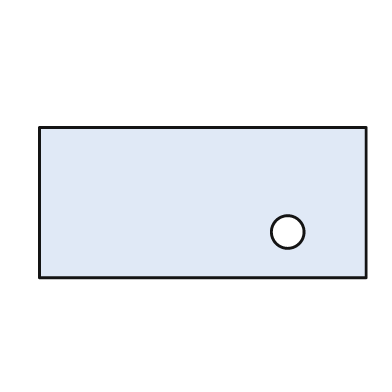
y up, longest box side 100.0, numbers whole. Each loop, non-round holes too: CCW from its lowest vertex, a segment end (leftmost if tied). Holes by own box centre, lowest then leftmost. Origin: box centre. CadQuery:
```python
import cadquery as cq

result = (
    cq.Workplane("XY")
    .moveTo(-50.0, -23.0)
    .lineTo(50.0, -23.0)
    .lineTo(50.0, 23.0)
    .lineTo(-50.0, 23.0)
    .close()
    .moveTo(26.0, -9.0)
    .circle(5.0)
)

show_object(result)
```